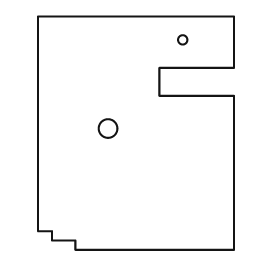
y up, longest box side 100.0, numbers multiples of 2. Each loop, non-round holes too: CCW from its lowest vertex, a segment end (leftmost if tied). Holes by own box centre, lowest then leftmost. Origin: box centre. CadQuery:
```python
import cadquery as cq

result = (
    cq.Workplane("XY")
    .moveTo(-26.0, -50.0)
    .lineTo(42.0, -50.0)
    .lineTo(42.0, 16.0)
    .lineTo(10.0, 16.0)
    .lineTo(10.0, 28.0)
    .lineTo(42.0, 28.0)
    .lineTo(42.0, 50.0)
    .lineTo(-42.0, 50.0)
    .lineTo(-42.0, -42.0)
    .lineTo(-36.0, -42.0)
    .lineTo(-36.0, -46.0)
    .lineTo(-26.0, -46.0)
    .close()
    .moveTo(-12.0, 2.0)
    .circle(4.0)
    .moveTo(20.0, 40.0)
    .circle(2.0)
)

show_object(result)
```